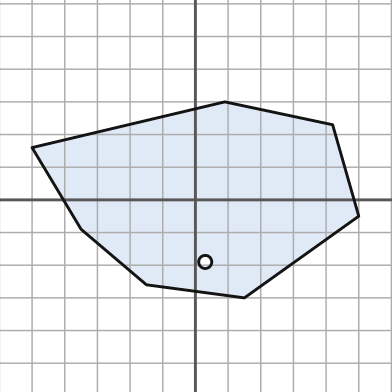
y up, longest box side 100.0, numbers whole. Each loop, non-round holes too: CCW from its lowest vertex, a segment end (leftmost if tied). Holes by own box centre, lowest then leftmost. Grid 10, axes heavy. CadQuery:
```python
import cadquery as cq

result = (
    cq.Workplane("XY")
    .moveTo(15.0, -30.0)
    .lineTo(50.0, -5.0)
    .lineTo(42.0, 23.0)
    .lineTo(9.0, 30.0)
    .lineTo(-50.0, 16.0)
    .lineTo(-35.0, -9.0)
    .lineTo(-15.0, -26.0)
    .close()
    .moveTo(3.0, -19.0)
    .circle(2.0)
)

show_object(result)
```